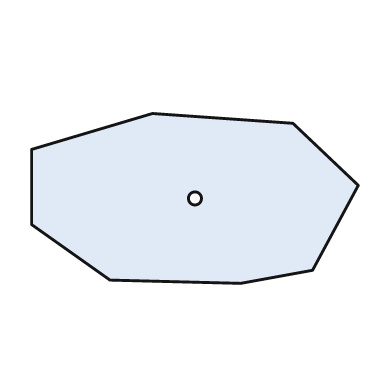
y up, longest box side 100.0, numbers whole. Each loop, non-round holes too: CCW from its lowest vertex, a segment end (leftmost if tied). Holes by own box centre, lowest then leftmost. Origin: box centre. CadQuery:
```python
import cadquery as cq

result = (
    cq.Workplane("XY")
    .moveTo(14.0, -26.0)
    .lineTo(36.0, -22.0)
    .lineTo(50.0, 4.0)
    .lineTo(30.0, 23.0)
    .lineTo(-13.0, 26.0)
    .lineTo(-50.0, 15.0)
    .lineTo(-50.0, -8.0)
    .lineTo(-26.0, -25.0)
    .close()
    .moveTo(0.0, 0.0)
    .circle(2.0)
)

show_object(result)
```